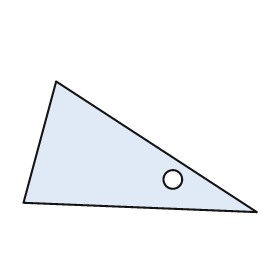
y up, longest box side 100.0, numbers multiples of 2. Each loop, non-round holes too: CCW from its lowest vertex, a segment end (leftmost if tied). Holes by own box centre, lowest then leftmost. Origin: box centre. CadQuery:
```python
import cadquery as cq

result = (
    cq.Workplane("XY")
    .moveTo(50.0, -28.0)
    .lineTo(-36.0, 28.0)
    .lineTo(-50.0, -24.0)
    .close()
    .moveTo(14.0, -14.0)
    .circle(4.0)
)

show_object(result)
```